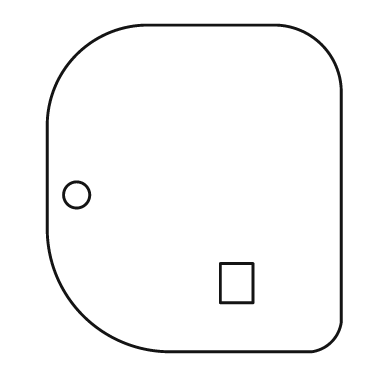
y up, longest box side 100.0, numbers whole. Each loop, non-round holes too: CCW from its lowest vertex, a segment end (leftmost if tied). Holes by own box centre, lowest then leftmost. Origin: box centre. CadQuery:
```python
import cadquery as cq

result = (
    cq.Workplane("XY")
    .moveTo(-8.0, -50.0)
    .lineTo(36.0, -50.0)
    .threePointArc((42.0, -47.0), (45.0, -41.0))
    .lineTo(45.0, 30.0)
    .threePointArc((39.0, 44.0), (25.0, 50.0))
    .lineTo(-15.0, 50.0)
    .threePointArc((-36.0, 41.0), (-45.0, 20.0))
    .lineTo(-45.0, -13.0)
    .threePointArc((-34.0, -39.0), (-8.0, -50.0))
    .close()
    .moveTo(8.0, -35.0)
    .lineTo(18.0, -35.0)
    .lineTo(18.0, -23.0)
    .lineTo(8.0, -23.0)
    .close()
    .moveTo(-36.0, -2.0)
    .circle(4.0)
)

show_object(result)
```